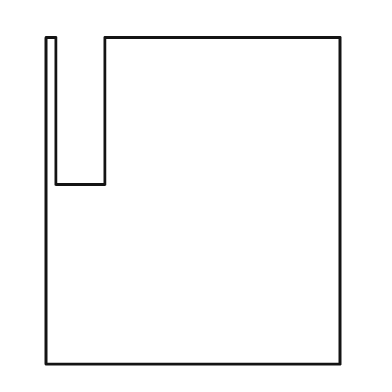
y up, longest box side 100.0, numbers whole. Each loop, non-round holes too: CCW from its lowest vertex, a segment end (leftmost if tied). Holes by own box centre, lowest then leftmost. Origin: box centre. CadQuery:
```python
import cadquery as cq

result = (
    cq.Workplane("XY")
    .moveTo(-45.0, -50.0)
    .lineTo(45.0, -50.0)
    .lineTo(45.0, 50.0)
    .lineTo(-27.0, 50.0)
    .lineTo(-27.0, 5.0)
    .lineTo(-42.0, 5.0)
    .lineTo(-42.0, 50.0)
    .lineTo(-45.0, 50.0)
    .close()
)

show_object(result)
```